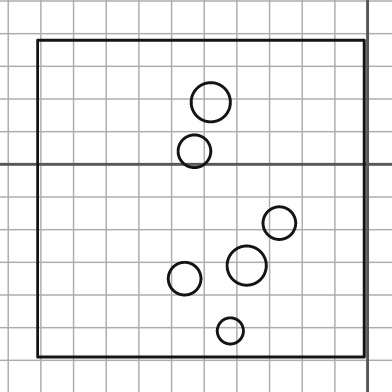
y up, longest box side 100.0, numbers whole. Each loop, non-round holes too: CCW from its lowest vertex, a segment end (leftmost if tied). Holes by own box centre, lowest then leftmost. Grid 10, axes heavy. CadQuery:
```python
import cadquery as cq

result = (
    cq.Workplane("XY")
    .moveTo(-101.0, -59.0)
    .lineTo(-1.0, -59.0)
    .lineTo(-1.0, 38.0)
    .lineTo(-101.0, 38.0)
    .close()
    .moveTo(-42.0, -51.0)
    .circle(4.0)
    .moveTo(-56.0, -35.0)
    .circle(5.0)
    .moveTo(-37.0, -31.0)
    .circle(6.0)
    .moveTo(-27.0, -18.0)
    .circle(5.0)
    .moveTo(-53.0, 4.0)
    .circle(5.0)
    .moveTo(-48.0, 19.0)
    .circle(6.0)
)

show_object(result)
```